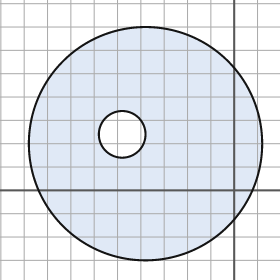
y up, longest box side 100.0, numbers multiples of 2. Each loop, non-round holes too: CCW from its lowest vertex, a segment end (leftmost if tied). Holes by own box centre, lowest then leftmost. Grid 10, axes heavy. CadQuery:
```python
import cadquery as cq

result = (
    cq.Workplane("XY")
    .moveTo(-38.0, 20.0)
    .circle(50.0)
    .moveTo(-48.0, 24.0)
    .circle(10.0)
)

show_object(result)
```